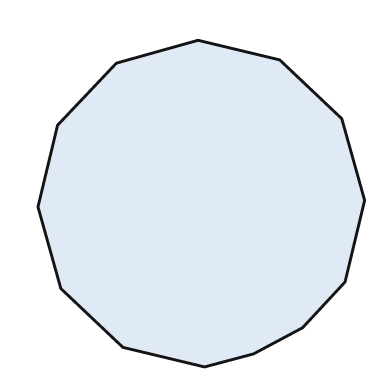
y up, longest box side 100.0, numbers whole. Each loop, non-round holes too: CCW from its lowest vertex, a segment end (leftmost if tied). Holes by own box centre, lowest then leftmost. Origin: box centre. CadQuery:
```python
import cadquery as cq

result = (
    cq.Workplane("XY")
    .moveTo(1.0, -50.0)
    .lineTo(16.0, -46.0)
    .lineTo(31.0, -38.0)
    .lineTo(44.0, -24.0)
    .lineTo(50.0, 1.0)
    .lineTo(43.0, 26.0)
    .lineTo(24.0, 44.0)
    .lineTo(-1.0, 50.0)
    .lineTo(-26.0, 43.0)
    .lineTo(-44.0, 24.0)
    .lineTo(-50.0, -1.0)
    .lineTo(-43.0, -26.0)
    .lineTo(-24.0, -44.0)
    .close()
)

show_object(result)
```